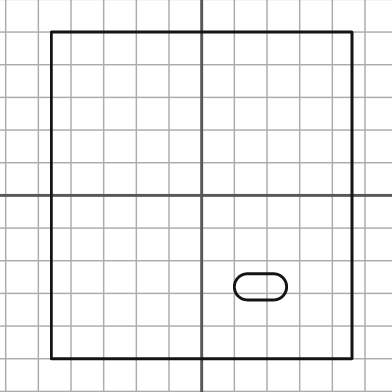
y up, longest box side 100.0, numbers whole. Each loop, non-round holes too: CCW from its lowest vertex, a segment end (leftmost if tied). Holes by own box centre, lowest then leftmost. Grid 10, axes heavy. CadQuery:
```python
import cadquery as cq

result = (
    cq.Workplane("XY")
    .moveTo(-46.0, -50.0)
    .lineTo(46.0, -50.0)
    .lineTo(46.0, 50.0)
    .lineTo(-46.0, 50.0)
    .close()
    .moveTo(14.0, -32.0)
    .lineTo(22.0, -32.0)
    .threePointArc((26.0, -28.0), (22.0, -24.0))
    .lineTo(14.0, -24.0)
    .threePointArc((10.0, -28.0), (14.0, -32.0))
    .close()
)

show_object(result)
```